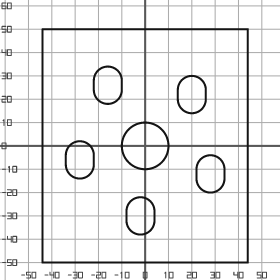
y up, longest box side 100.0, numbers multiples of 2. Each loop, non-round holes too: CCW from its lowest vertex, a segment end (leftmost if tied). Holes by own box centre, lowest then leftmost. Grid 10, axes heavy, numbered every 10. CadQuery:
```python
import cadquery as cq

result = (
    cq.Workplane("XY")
    .moveTo(-44.0, -50.0)
    .lineTo(44.0, -50.0)
    .lineTo(44.0, 50.0)
    .lineTo(-44.0, 50.0)
    .close()
    .moveTo(-8.0, -32.0)
    .threePointArc((-2.0, -38.0), (4.0, -32.0))
    .lineTo(4.0, -28.0)
    .threePointArc((-2.0, -22.0), (-8.0, -28.0))
    .close()
    .moveTo(22.0, -14.0)
    .threePointArc((28.0, -20.0), (34.0, -14.0))
    .lineTo(34.0, -10.0)
    .threePointArc((28.0, -4.0), (22.0, -10.0))
    .close()
    .moveTo(-34.0, -8.0)
    .threePointArc((-28.0, -14.0), (-22.0, -8.0))
    .lineTo(-22.0, -4.0)
    .threePointArc((-28.0, 2.0), (-34.0, -4.0))
    .close()
    .moveTo(0.0, 0.0)
    .circle(10.0)
    .moveTo(14.0, 20.0)
    .threePointArc((20.0, 14.0), (26.0, 20.0))
    .lineTo(26.0, 24.0)
    .threePointArc((20.0, 30.0), (14.0, 24.0))
    .close()
    .moveTo(-22.0, 24.0)
    .threePointArc((-16.0, 18.0), (-10.0, 24.0))
    .lineTo(-10.0, 28.0)
    .threePointArc((-16.0, 34.0), (-22.0, 28.0))
    .close()
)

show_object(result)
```